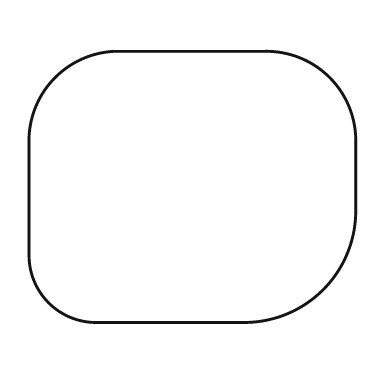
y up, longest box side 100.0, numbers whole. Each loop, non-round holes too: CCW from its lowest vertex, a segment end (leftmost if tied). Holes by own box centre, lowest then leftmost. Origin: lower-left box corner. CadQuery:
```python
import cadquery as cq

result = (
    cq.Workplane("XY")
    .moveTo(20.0, 0.0)
    .lineTo(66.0, 0.0)
    .threePointArc((90.0, 10.0), (100.0, 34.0))
    .lineTo(100.0, 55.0)
    .threePointArc((92.0, 75.0), (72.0, 83.0))
    .lineTo(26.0, 83.0)
    .threePointArc((8.0, 75.0), (0.0, 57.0))
    .lineTo(0.0, 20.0)
    .threePointArc((6.0, 6.0), (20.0, 0.0))
    .close()
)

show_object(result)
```